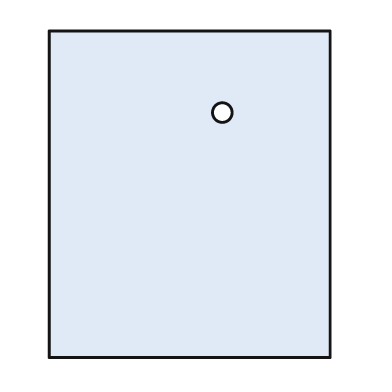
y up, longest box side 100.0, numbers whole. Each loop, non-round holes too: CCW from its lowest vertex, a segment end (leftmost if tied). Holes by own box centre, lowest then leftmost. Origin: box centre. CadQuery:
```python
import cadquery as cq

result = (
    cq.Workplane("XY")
    .moveTo(-43.0, -50.0)
    .lineTo(43.0, -50.0)
    .lineTo(43.0, 50.0)
    .lineTo(-43.0, 50.0)
    .close()
    .moveTo(10.0, 25.0)
    .circle(3.0)
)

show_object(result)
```